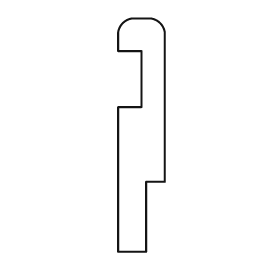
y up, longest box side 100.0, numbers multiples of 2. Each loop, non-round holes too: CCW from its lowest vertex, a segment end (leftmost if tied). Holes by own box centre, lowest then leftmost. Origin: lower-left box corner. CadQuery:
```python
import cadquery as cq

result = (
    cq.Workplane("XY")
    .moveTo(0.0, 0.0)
    .lineTo(12.0, 0.0)
    .lineTo(12.0, 30.0)
    .lineTo(20.0, 30.0)
    .lineTo(20.0, 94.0)
    .threePointArc((18.0, 98.0), (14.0, 100.0))
    .lineTo(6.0, 100.0)
    .threePointArc((2.0, 98.0), (0.0, 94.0))
    .lineTo(0.0, 86.0)
    .lineTo(10.0, 86.0)
    .lineTo(10.0, 62.0)
    .lineTo(0.0, 62.0)
    .close()
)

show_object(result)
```